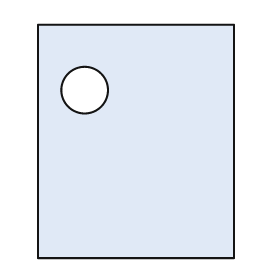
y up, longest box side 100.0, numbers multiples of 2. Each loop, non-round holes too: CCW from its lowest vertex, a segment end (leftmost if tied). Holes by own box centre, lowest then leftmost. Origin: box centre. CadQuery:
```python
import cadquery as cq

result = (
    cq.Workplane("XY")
    .moveTo(-42.0, -50.0)
    .lineTo(42.0, -50.0)
    .lineTo(42.0, 50.0)
    .lineTo(-42.0, 50.0)
    .close()
    .moveTo(-22.0, 22.0)
    .circle(10.0)
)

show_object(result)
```